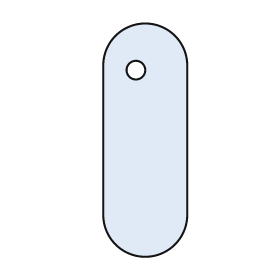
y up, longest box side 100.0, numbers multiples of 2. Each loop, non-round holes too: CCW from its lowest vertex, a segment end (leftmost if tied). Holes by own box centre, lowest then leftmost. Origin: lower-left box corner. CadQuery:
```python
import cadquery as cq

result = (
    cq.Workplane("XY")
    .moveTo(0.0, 18.0)
    .threePointArc((18.0, 0.0), (36.0, 18.0))
    .lineTo(36.0, 82.0)
    .threePointArc((18.0, 100.0), (0.0, 82.0))
    .close()
    .moveTo(14.0, 80.0)
    .circle(4.0)
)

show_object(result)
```